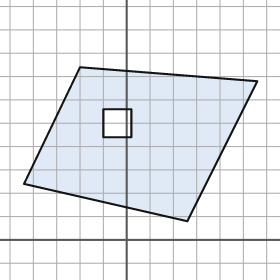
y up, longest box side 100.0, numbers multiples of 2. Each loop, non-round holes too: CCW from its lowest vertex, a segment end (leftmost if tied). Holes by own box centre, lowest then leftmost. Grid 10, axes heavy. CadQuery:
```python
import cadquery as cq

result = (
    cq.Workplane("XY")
    .moveTo(26.0, 8.0)
    .lineTo(56.0, 68.0)
    .lineTo(-20.0, 74.0)
    .lineTo(-44.0, 24.0)
    .close()
    .moveTo(-10.0, 44.0)
    .lineTo(2.0, 44.0)
    .lineTo(2.0, 56.0)
    .lineTo(-10.0, 56.0)
    .close()
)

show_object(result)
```